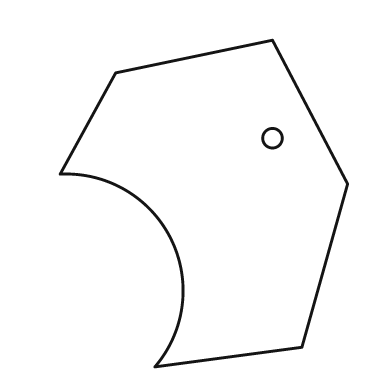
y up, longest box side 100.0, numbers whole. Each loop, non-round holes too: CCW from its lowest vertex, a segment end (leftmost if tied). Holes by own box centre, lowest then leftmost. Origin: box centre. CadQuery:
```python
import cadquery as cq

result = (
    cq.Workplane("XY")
    .moveTo(-15.0, -50.0)
    .lineTo(30.0, -44.0)
    .lineTo(44.0, 6.0)
    .lineTo(21.0, 50.0)
    .lineTo(-27.0, 40.0)
    .lineTo(-44.0, 9.0)
    .threePointArc((-10.0, -11.0), (-15.0, -50.0))
    .close()
    .moveTo(21.0, 20.0)
    .circle(3.0)
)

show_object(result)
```